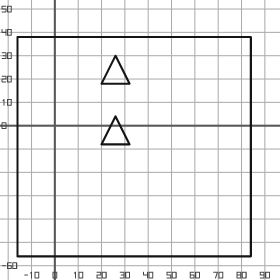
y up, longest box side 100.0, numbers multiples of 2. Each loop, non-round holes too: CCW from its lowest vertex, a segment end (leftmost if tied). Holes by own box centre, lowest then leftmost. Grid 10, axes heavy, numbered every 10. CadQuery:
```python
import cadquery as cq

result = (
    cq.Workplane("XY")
    .moveTo(-16.0, -56.0)
    .lineTo(84.0, -56.0)
    .lineTo(84.0, 38.0)
    .lineTo(-16.0, 38.0)
    .close()
    .moveTo(20.0, -8.0)
    .lineTo(32.0, -8.0)
    .lineTo(26.0, 4.0)
    .close()
    .moveTo(20.0, 18.0)
    .lineTo(32.0, 18.0)
    .lineTo(26.0, 30.0)
    .close()
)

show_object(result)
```